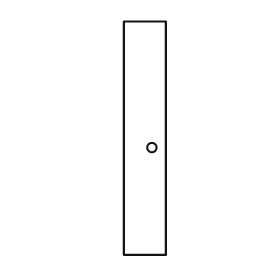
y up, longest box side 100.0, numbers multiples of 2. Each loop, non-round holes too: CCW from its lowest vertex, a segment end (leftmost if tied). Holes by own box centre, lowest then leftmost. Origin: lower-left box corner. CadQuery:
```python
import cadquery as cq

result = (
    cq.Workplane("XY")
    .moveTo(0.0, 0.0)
    .lineTo(18.0, 0.0)
    .lineTo(18.0, 100.0)
    .lineTo(0.0, 100.0)
    .close()
    .moveTo(12.0, 46.0)
    .circle(2.0)
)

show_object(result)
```